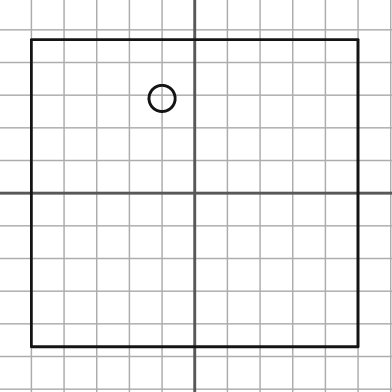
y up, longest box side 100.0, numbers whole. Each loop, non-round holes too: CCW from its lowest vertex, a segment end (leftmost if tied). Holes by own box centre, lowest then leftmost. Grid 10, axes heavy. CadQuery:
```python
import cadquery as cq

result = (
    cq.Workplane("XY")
    .moveTo(-50.0, -47.0)
    .lineTo(50.0, -47.0)
    .lineTo(50.0, 47.0)
    .lineTo(-50.0, 47.0)
    .close()
    .moveTo(-10.0, 29.0)
    .circle(4.0)
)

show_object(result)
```